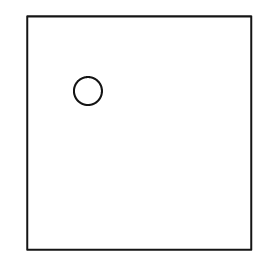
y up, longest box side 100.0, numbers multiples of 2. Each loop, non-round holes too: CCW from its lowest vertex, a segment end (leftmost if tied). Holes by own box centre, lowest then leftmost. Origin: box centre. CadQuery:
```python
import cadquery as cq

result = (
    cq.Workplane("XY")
    .moveTo(-48.0, -50.0)
    .lineTo(48.0, -50.0)
    .lineTo(48.0, 50.0)
    .lineTo(-48.0, 50.0)
    .close()
    .moveTo(-22.0, 18.0)
    .circle(6.0)
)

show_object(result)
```